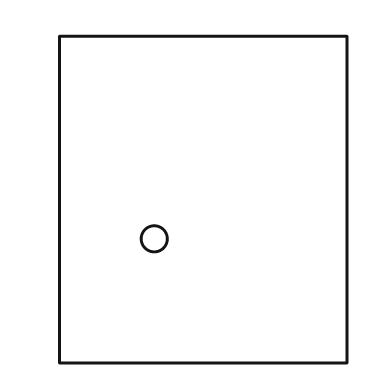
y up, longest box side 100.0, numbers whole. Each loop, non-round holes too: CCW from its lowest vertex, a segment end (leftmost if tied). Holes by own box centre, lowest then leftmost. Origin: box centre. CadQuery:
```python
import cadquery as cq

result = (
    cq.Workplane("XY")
    .moveTo(-44.0, -50.0)
    .lineTo(44.0, -50.0)
    .lineTo(44.0, 50.0)
    .lineTo(-44.0, 50.0)
    .close()
    .moveTo(-15.0, -12.0)
    .circle(4.0)
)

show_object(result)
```